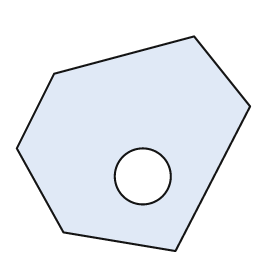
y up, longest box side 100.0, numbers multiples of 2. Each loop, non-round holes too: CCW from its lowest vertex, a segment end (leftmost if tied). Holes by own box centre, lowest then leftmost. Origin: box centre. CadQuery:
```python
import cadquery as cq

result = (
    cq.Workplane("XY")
    .moveTo(18.0, -46.0)
    .lineTo(50.0, 16.0)
    .lineTo(26.0, 46.0)
    .lineTo(-34.0, 30.0)
    .lineTo(-50.0, -2.0)
    .lineTo(-30.0, -38.0)
    .close()
    .moveTo(4.0, -14.0)
    .circle(12.0)
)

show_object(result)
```